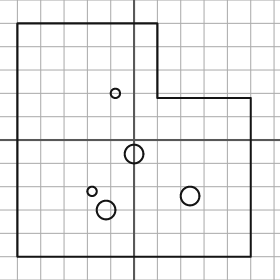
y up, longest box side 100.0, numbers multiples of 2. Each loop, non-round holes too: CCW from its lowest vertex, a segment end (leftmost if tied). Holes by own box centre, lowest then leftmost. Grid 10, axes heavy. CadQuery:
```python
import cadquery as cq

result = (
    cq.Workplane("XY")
    .moveTo(-50.0, -50.0)
    .lineTo(50.0, -50.0)
    .lineTo(50.0, 18.0)
    .lineTo(10.0, 18.0)
    .lineTo(10.0, 50.0)
    .lineTo(-50.0, 50.0)
    .close()
    .moveTo(-12.0, -30.0)
    .circle(4.0)
    .moveTo(24.0, -24.0)
    .circle(4.0)
    .moveTo(-18.0, -22.0)
    .circle(2.0)
    .moveTo(0.0, -6.0)
    .circle(4.0)
    .moveTo(-8.0, 20.0)
    .circle(2.0)
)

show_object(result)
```